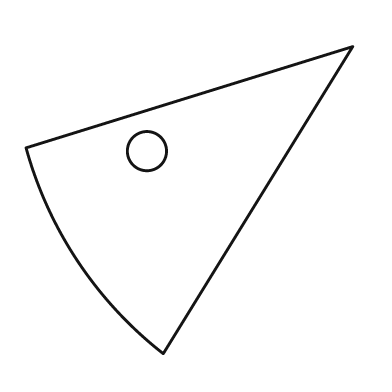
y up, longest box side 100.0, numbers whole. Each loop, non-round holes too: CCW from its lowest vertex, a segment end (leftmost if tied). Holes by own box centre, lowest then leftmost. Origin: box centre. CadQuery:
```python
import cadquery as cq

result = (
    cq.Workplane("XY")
    .moveTo(-8.0, -47.0)
    .lineTo(50.0, 47.0)
    .lineTo(-50.0, 16.0)
    .threePointArc((-34.0, -19.0), (-8.0, -47.0))
    .close()
    .moveTo(-13.0, 15.0)
    .circle(6.0)
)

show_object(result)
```